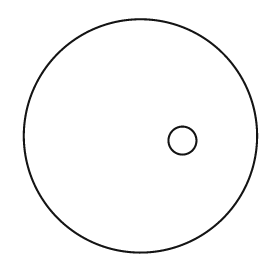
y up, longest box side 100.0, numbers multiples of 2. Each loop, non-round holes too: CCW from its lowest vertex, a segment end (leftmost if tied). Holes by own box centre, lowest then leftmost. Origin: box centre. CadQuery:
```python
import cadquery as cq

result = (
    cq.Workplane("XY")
    .moveTo(0.0, 0.0)
    .circle(50.0)
    .moveTo(18.0, -2.0)
    .circle(6.0)
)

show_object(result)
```